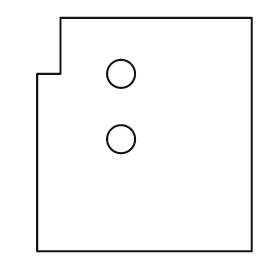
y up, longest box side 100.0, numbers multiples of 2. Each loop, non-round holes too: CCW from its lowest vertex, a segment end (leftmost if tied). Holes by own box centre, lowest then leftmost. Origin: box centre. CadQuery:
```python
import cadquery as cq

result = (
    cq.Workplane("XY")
    .moveTo(-46.0, -50.0)
    .lineTo(46.0, -50.0)
    .lineTo(46.0, 50.0)
    .lineTo(-36.0, 50.0)
    .lineTo(-36.0, 26.0)
    .lineTo(-46.0, 26.0)
    .close()
    .moveTo(-10.0, -2.0)
    .circle(6.0)
    .moveTo(-10.0, 26.0)
    .circle(6.0)
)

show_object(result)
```